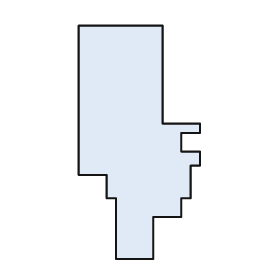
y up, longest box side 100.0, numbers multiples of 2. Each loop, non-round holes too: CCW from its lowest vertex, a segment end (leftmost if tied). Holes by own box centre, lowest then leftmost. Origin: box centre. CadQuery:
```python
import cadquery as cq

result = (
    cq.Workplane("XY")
    .moveTo(-10.0, -50.0)
    .lineTo(6.0, -50.0)
    .lineTo(6.0, -32.0)
    .lineTo(18.0, -32.0)
    .lineTo(18.0, -24.0)
    .lineTo(22.0, -24.0)
    .lineTo(22.0, -10.0)
    .lineTo(26.0, -10.0)
    .lineTo(26.0, -4.0)
    .lineTo(18.0, -4.0)
    .lineTo(18.0, 4.0)
    .lineTo(26.0, 4.0)
    .lineTo(26.0, 8.0)
    .lineTo(10.0, 8.0)
    .lineTo(10.0, 50.0)
    .lineTo(-26.0, 50.0)
    .lineTo(-26.0, -14.0)
    .lineTo(-14.0, -14.0)
    .lineTo(-14.0, -24.0)
    .lineTo(-10.0, -24.0)
    .close()
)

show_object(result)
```